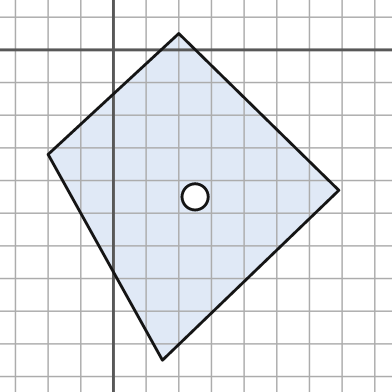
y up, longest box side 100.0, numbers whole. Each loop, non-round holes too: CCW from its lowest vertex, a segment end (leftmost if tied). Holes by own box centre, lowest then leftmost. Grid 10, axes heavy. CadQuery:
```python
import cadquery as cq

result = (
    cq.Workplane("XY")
    .moveTo(15.0, -95.0)
    .lineTo(69.0, -43.0)
    .lineTo(20.0, 5.0)
    .lineTo(-20.0, -32.0)
    .close()
    .moveTo(25.0, -45.0)
    .circle(4.0)
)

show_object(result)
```